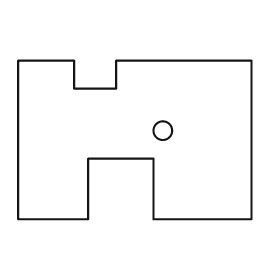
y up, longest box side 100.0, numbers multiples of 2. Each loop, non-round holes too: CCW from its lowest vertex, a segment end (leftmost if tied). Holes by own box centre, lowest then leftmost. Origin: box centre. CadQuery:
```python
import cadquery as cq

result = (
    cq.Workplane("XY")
    .moveTo(-50.0, -34.0)
    .lineTo(-20.0, -34.0)
    .lineTo(-20.0, -8.0)
    .lineTo(8.0, -8.0)
    .lineTo(8.0, -34.0)
    .lineTo(50.0, -34.0)
    .lineTo(50.0, 34.0)
    .lineTo(-8.0, 34.0)
    .lineTo(-8.0, 22.0)
    .lineTo(-26.0, 22.0)
    .lineTo(-26.0, 34.0)
    .lineTo(-50.0, 34.0)
    .close()
    .moveTo(12.0, 4.0)
    .circle(4.0)
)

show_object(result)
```